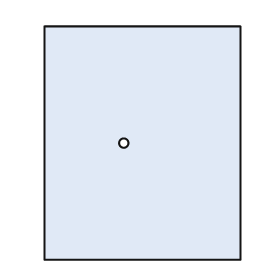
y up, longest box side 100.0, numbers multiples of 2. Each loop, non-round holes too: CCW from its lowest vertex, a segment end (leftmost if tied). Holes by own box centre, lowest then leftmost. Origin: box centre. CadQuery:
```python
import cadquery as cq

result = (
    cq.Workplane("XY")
    .moveTo(-42.0, -50.0)
    .lineTo(42.0, -50.0)
    .lineTo(42.0, 50.0)
    .lineTo(-42.0, 50.0)
    .close()
    .moveTo(-8.0, 0.0)
    .circle(2.0)
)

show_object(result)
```